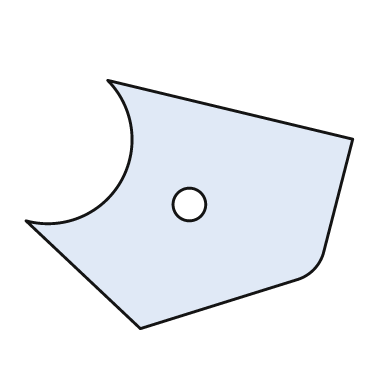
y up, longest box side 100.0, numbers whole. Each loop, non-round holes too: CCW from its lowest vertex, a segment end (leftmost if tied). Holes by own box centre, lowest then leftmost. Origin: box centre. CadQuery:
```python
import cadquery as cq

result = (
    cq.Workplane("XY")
    .moveTo(-15.0, -38.0)
    .lineTo(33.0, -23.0)
    .threePointArc((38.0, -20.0), (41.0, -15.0))
    .lineTo(50.0, 20.0)
    .lineTo(-25.0, 38.0)
    .threePointArc((-21.0, 7.0), (-50.0, -5.0))
    .close()
    .moveTo(0.0, 0.0)
    .circle(5.0)
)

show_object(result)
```